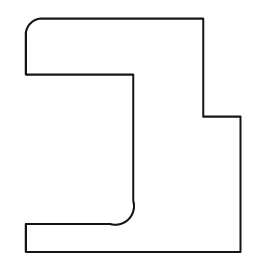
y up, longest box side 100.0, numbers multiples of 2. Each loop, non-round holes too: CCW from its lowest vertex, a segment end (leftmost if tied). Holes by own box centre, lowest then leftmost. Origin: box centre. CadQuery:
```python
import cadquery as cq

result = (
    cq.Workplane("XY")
    .moveTo(-46.0, -50.0)
    .lineTo(46.0, -50.0)
    .lineTo(46.0, 8.0)
    .lineTo(30.0, 8.0)
    .lineTo(30.0, 50.0)
    .lineTo(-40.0, 50.0)
    .threePointArc((-44.0, 48.0), (-46.0, 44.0))
    .lineTo(-46.0, 26.0)
    .lineTo(0.0, 26.0)
    .lineTo(0.0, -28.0)
    .threePointArc((-2.0, -36.0), (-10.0, -38.0))
    .lineTo(-46.0, -38.0)
    .close()
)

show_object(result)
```